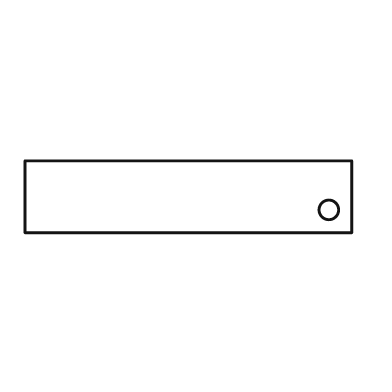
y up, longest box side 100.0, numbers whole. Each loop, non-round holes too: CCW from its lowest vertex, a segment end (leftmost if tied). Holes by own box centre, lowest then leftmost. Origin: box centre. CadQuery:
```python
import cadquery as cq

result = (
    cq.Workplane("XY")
    .moveTo(-50.0, -11.0)
    .lineTo(50.0, -11.0)
    .lineTo(50.0, 11.0)
    .lineTo(-50.0, 11.0)
    .close()
    .moveTo(43.0, -4.0)
    .circle(3.0)
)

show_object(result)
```